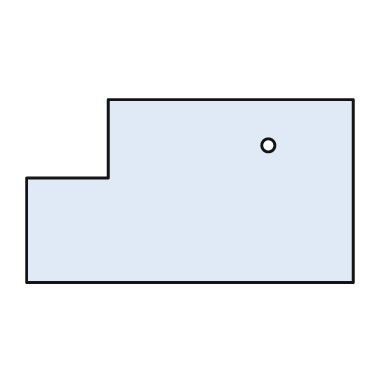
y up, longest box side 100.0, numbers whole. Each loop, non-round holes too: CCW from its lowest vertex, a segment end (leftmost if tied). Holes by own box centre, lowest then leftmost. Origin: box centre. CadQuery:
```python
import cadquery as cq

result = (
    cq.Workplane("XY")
    .moveTo(-50.0, -28.0)
    .lineTo(50.0, -28.0)
    .lineTo(50.0, 28.0)
    .lineTo(-25.0, 28.0)
    .lineTo(-25.0, 4.0)
    .lineTo(-50.0, 4.0)
    .close()
    .moveTo(24.0, 14.0)
    .circle(2.0)
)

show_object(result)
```